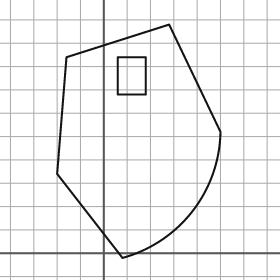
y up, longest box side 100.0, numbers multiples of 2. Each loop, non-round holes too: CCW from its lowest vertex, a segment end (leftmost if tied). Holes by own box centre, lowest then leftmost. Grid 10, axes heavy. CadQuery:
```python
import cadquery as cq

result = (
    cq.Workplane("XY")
    .moveTo(8.0, -2.0)
    .threePointArc((38.0, 18.0), (50.0, 52.0))
    .lineTo(28.0, 98.0)
    .lineTo(-16.0, 84.0)
    .lineTo(-20.0, 34.0)
    .close()
    .moveTo(6.0, 68.0)
    .lineTo(18.0, 68.0)
    .lineTo(18.0, 84.0)
    .lineTo(6.0, 84.0)
    .close()
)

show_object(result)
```